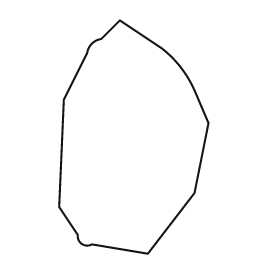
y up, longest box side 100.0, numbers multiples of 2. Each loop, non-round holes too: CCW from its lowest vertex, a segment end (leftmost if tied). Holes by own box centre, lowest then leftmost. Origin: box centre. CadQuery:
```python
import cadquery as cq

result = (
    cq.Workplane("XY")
    .moveTo(6.0, -50.0)
    .lineTo(26.0, -24.0)
    .lineTo(32.0, 6.0)
    .lineTo(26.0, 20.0)
    .threePointArc((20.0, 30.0), (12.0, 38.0))
    .lineTo(-6.0, 50.0)
    .lineTo(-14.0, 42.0)
    .threePointArc((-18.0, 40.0), (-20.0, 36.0))
    .lineTo(-30.0, 16.0)
    .lineTo(-32.0, -30.0)
    .lineTo(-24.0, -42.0)
    .threePointArc((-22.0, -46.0), (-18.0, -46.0))
    .close()
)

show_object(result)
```